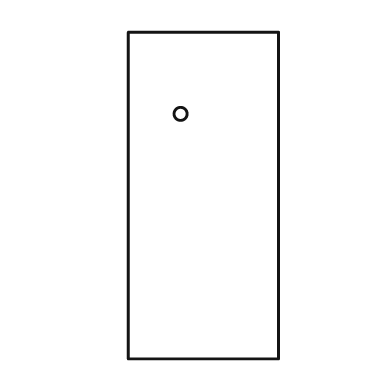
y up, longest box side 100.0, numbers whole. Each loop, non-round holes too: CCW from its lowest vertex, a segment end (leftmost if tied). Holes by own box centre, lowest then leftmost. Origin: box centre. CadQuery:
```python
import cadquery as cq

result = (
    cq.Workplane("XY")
    .moveTo(-23.0, -50.0)
    .lineTo(23.0, -50.0)
    .lineTo(23.0, 50.0)
    .lineTo(-23.0, 50.0)
    .close()
    .moveTo(-7.0, 25.0)
    .circle(2.0)
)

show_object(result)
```